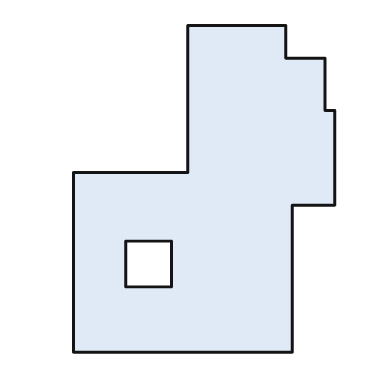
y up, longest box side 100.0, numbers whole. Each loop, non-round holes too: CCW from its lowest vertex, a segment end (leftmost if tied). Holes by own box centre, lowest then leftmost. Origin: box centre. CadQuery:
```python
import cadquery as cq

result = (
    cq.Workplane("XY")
    .moveTo(-40.0, -50.0)
    .lineTo(27.0, -50.0)
    .lineTo(27.0, -5.0)
    .lineTo(40.0, -5.0)
    .lineTo(40.0, 24.0)
    .lineTo(37.0, 24.0)
    .lineTo(37.0, 40.0)
    .lineTo(25.0, 40.0)
    .lineTo(25.0, 50.0)
    .lineTo(-5.0, 50.0)
    .lineTo(-5.0, 5.0)
    .lineTo(-40.0, 5.0)
    .close()
    .moveTo(-24.0, -30.0)
    .lineTo(-10.0, -30.0)
    .lineTo(-10.0, -16.0)
    .lineTo(-24.0, -16.0)
    .close()
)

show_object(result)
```